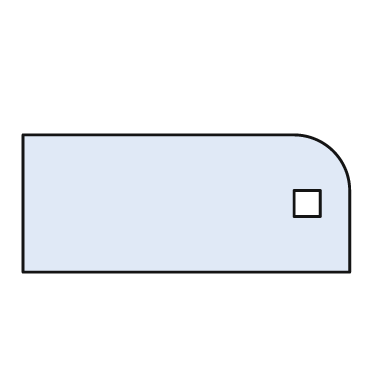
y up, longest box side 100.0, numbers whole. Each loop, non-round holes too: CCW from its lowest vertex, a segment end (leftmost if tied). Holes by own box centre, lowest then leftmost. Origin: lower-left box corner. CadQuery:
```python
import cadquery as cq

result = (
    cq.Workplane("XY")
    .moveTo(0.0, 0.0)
    .lineTo(100.0, 0.0)
    .lineTo(100.0, 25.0)
    .threePointArc((95.0, 37.0), (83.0, 42.0))
    .lineTo(0.0, 42.0)
    .close()
    .moveTo(83.0, 17.0)
    .lineTo(91.0, 17.0)
    .lineTo(91.0, 25.0)
    .lineTo(83.0, 25.0)
    .close()
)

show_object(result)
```